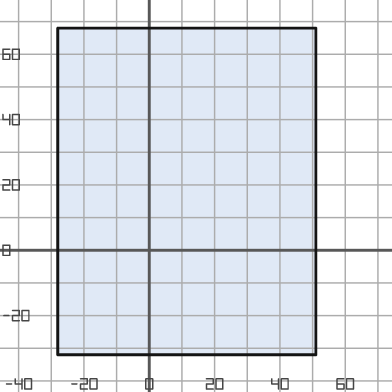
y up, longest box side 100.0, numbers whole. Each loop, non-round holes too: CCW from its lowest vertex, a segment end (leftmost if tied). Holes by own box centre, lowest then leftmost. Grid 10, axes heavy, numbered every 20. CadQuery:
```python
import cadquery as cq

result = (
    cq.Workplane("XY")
    .moveTo(-28.0, -32.0)
    .lineTo(51.0, -32.0)
    .lineTo(51.0, 68.0)
    .lineTo(-28.0, 68.0)
    .close()
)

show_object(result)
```